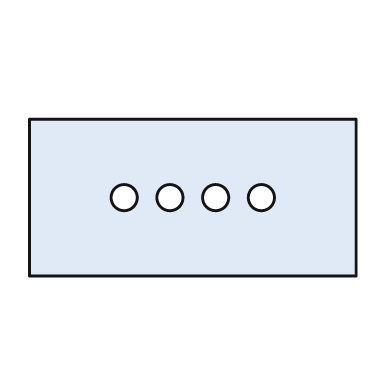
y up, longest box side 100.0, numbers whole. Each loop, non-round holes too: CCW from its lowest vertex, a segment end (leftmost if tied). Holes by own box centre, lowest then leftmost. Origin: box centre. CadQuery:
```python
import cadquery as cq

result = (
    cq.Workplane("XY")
    .moveTo(-50.0, -24.0)
    .lineTo(50.0, -24.0)
    .lineTo(50.0, 24.0)
    .lineTo(-50.0, 24.0)
    .close()
    .moveTo(-21.0, 0.0)
    .circle(4.0)
    .moveTo(-7.0, 0.0)
    .circle(4.0)
    .moveTo(7.0, 0.0)
    .circle(4.0)
    .moveTo(21.0, 0.0)
    .circle(4.0)
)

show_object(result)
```